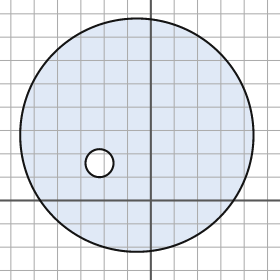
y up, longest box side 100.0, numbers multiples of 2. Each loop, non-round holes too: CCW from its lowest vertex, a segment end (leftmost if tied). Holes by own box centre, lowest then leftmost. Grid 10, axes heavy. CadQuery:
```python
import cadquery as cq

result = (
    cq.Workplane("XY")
    .moveTo(-6.0, 28.0)
    .circle(50.0)
    .moveTo(-22.0, 16.0)
    .circle(6.0)
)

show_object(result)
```